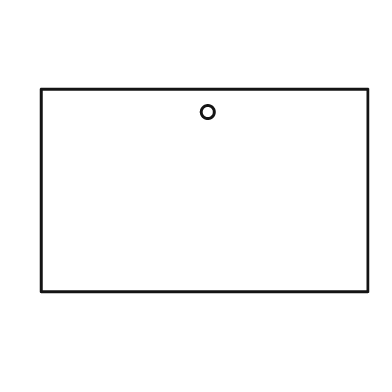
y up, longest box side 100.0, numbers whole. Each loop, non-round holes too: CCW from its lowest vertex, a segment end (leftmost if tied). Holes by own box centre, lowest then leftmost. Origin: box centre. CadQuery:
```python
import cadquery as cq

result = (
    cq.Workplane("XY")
    .moveTo(-50.0, -31.0)
    .lineTo(50.0, -31.0)
    .lineTo(50.0, 31.0)
    .lineTo(-50.0, 31.0)
    .close()
    .moveTo(1.0, 24.0)
    .circle(2.0)
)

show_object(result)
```